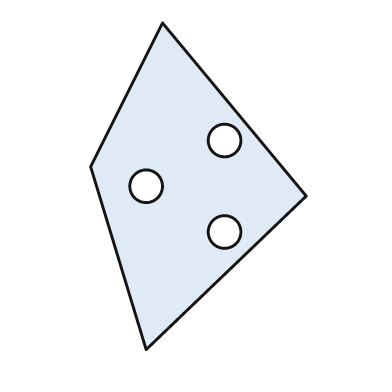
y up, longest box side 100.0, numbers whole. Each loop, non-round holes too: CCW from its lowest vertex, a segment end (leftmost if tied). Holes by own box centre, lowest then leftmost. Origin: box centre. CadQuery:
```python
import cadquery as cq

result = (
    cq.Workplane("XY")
    .moveTo(-16.0, -50.0)
    .lineTo(33.0, -3.0)
    .lineTo(-11.0, 50.0)
    .lineTo(-33.0, 6.0)
    .close()
    .moveTo(8.0, -14.0)
    .circle(5.0)
    .moveTo(-16.0, 0.0)
    .circle(5.0)
    .moveTo(8.0, 14.0)
    .circle(5.0)
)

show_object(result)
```